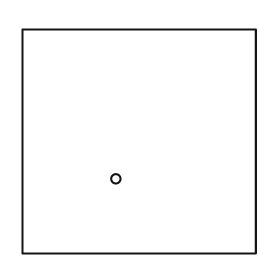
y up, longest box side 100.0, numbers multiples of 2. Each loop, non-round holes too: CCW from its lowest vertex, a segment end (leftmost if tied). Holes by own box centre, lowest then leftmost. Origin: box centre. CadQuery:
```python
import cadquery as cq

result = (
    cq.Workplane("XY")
    .moveTo(-50.0, -48.0)
    .lineTo(50.0, -48.0)
    .lineTo(50.0, 48.0)
    .lineTo(-50.0, 48.0)
    .close()
    .moveTo(-10.0, -16.0)
    .circle(2.0)
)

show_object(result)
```